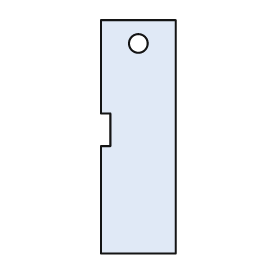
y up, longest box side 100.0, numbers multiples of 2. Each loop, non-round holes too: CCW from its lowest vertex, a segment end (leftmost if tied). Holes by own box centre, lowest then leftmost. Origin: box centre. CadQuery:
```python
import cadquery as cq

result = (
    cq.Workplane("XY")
    .moveTo(-16.0, -50.0)
    .lineTo(16.0, -50.0)
    .lineTo(16.0, 50.0)
    .lineTo(-16.0, 50.0)
    .lineTo(-16.0, 10.0)
    .lineTo(-12.0, 10.0)
    .lineTo(-12.0, -4.0)
    .lineTo(-16.0, -4.0)
    .close()
    .moveTo(0.0, 40.0)
    .circle(4.0)
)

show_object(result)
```